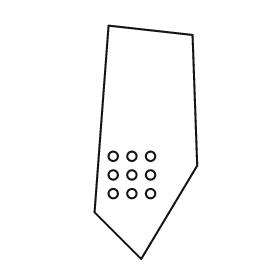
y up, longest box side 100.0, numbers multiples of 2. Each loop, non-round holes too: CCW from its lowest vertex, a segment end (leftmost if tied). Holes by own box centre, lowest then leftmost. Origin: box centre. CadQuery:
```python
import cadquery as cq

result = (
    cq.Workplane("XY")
    .moveTo(-2.0, -50.0)
    .lineTo(22.0, -10.0)
    .lineTo(20.0, 46.0)
    .lineTo(-16.0, 50.0)
    .lineTo(-22.0, -30.0)
    .close()
    .moveTo(-14.0, -22.0)
    .circle(2.0)
    .moveTo(-6.0, -22.0)
    .circle(2.0)
    .moveTo(2.0, -22.0)
    .circle(2.0)
    .moveTo(-14.0, -14.0)
    .circle(2.0)
    .moveTo(-6.0, -14.0)
    .circle(2.0)
    .moveTo(2.0, -14.0)
    .circle(2.0)
    .moveTo(-14.0, -6.0)
    .circle(2.0)
    .moveTo(-6.0, -6.0)
    .circle(2.0)
    .moveTo(2.0, -6.0)
    .circle(2.0)
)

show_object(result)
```